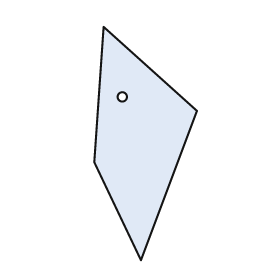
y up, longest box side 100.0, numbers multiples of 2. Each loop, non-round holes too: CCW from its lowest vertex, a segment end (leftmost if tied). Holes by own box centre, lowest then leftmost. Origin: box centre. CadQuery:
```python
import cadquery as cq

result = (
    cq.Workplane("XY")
    .moveTo(-2.0, -50.0)
    .lineTo(22.0, 14.0)
    .lineTo(-18.0, 50.0)
    .lineTo(-22.0, -8.0)
    .close()
    .moveTo(-10.0, 20.0)
    .circle(2.0)
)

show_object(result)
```